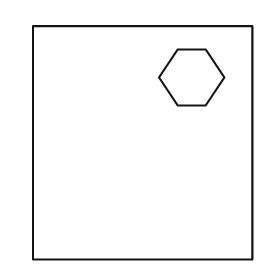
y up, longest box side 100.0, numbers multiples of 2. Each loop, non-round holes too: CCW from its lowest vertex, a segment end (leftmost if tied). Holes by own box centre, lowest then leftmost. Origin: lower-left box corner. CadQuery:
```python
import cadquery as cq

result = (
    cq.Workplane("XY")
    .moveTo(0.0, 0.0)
    .lineTo(94.0, 0.0)
    .lineTo(94.0, 100.0)
    .lineTo(0.0, 100.0)
    .close()
    .moveTo(62.0, 66.0)
    .lineTo(74.0, 66.0)
    .lineTo(82.0, 78.0)
    .lineTo(74.0, 90.0)
    .lineTo(62.0, 90.0)
    .lineTo(54.0, 78.0)
    .close()
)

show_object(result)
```